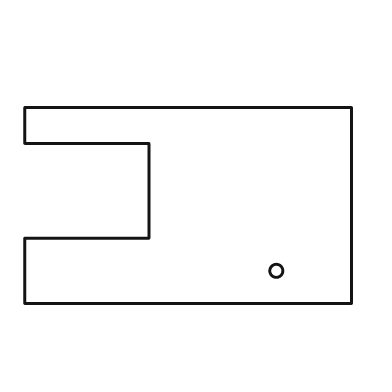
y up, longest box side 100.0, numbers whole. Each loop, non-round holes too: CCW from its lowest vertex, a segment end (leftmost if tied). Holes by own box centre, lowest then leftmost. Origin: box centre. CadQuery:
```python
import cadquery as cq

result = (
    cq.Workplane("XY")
    .moveTo(-50.0, -30.0)
    .lineTo(50.0, -30.0)
    .lineTo(50.0, 30.0)
    .lineTo(-50.0, 30.0)
    .lineTo(-50.0, 19.0)
    .lineTo(-12.0, 19.0)
    .lineTo(-12.0, -10.0)
    .lineTo(-50.0, -10.0)
    .close()
    .moveTo(27.0, -20.0)
    .circle(2.0)
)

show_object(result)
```